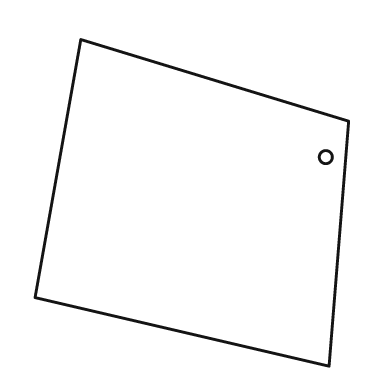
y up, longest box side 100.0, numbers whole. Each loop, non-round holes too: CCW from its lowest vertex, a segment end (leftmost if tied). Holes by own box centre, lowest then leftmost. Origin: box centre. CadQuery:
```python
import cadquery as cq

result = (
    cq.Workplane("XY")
    .moveTo(42.0, -50.0)
    .lineTo(48.0, 25.0)
    .lineTo(-34.0, 50.0)
    .lineTo(-48.0, -29.0)
    .close()
    .moveTo(41.0, 14.0)
    .circle(2.0)
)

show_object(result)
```